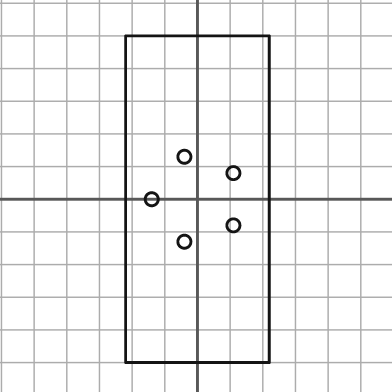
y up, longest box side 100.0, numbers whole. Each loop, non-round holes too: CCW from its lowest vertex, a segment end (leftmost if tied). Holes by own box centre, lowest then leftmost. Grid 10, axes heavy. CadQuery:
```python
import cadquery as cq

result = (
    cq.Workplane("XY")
    .moveTo(-22.0, -50.0)
    .lineTo(22.0, -50.0)
    .lineTo(22.0, 50.0)
    .lineTo(-22.0, 50.0)
    .close()
    .moveTo(-4.0, -13.0)
    .circle(2.0)
    .moveTo(11.0, -8.0)
    .circle(2.0)
    .moveTo(-14.0, 0.0)
    .circle(2.0)
    .moveTo(11.0, 8.0)
    .circle(2.0)
    .moveTo(-4.0, 13.0)
    .circle(2.0)
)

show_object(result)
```